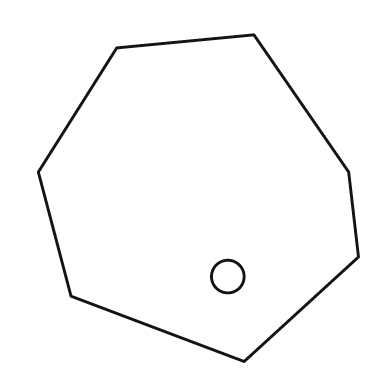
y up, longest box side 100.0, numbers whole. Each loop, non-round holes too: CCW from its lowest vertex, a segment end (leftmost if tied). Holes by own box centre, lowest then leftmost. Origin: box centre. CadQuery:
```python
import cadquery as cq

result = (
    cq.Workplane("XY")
    .moveTo(14.0, -50.0)
    .lineTo(49.0, -18.0)
    .lineTo(46.0, 8.0)
    .lineTo(17.0, 50.0)
    .lineTo(-25.0, 46.0)
    .lineTo(-49.0, 8.0)
    .lineTo(-39.0, -30.0)
    .close()
    .moveTo(9.0, -24.0)
    .circle(5.0)
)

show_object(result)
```